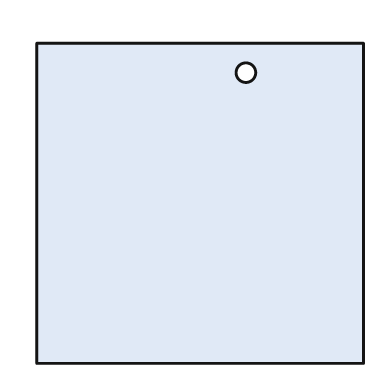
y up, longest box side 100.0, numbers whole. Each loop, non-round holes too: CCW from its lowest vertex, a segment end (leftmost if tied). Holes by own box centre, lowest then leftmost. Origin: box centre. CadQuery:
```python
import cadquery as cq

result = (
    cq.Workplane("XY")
    .moveTo(-50.0, -49.0)
    .lineTo(50.0, -49.0)
    .lineTo(50.0, 49.0)
    .lineTo(-50.0, 49.0)
    .close()
    .moveTo(14.0, 40.0)
    .circle(3.0)
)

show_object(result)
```